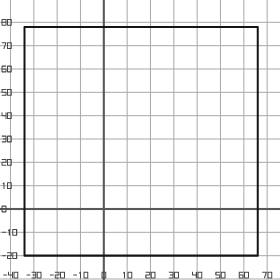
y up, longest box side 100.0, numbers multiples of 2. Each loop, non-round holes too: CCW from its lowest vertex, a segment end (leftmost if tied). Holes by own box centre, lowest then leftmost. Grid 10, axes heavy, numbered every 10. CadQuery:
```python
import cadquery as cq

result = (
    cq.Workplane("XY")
    .moveTo(-34.0, -20.0)
    .lineTo(66.0, -20.0)
    .lineTo(66.0, 78.0)
    .lineTo(-34.0, 78.0)
    .close()
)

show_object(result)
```